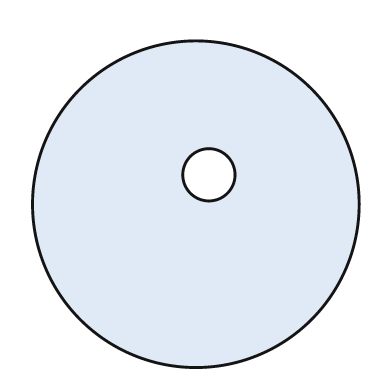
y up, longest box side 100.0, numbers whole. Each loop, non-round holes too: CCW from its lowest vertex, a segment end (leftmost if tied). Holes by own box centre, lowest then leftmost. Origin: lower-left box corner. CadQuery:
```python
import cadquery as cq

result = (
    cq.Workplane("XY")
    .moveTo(50.0, 50.0)
    .circle(50.0)
    .moveTo(54.0, 59.0)
    .circle(8.0)
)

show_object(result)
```